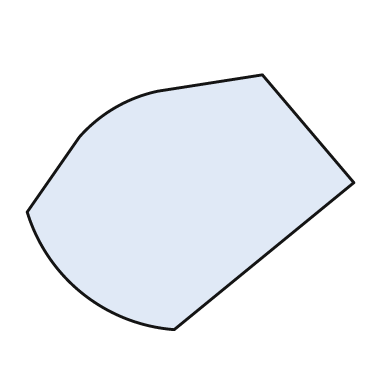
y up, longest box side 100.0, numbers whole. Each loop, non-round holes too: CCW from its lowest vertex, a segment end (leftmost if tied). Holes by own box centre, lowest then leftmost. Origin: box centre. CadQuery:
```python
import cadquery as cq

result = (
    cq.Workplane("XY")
    .moveTo(-5.0, -39.0)
    .lineTo(50.0, 6.0)
    .lineTo(22.0, 39.0)
    .lineTo(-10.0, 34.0)
    .threePointArc((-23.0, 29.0), (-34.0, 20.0))
    .lineTo(-50.0, -3.0)
    .threePointArc((-33.0, -28.0), (-5.0, -39.0))
    .close()
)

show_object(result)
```